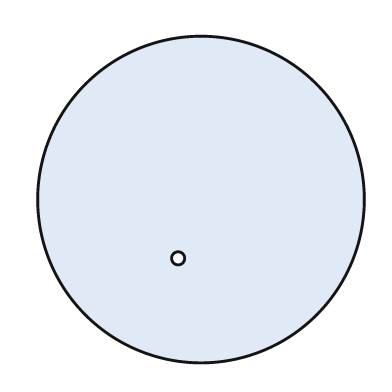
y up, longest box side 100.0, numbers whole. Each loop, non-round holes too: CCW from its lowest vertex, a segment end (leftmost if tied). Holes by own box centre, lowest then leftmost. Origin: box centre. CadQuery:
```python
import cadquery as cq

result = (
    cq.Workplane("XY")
    .moveTo(0.0, 0.0)
    .circle(50.0)
    .moveTo(-7.0, -18.0)
    .circle(2.0)
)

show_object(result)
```